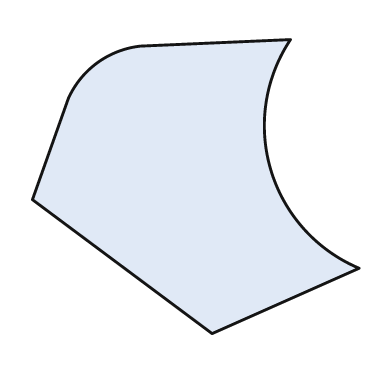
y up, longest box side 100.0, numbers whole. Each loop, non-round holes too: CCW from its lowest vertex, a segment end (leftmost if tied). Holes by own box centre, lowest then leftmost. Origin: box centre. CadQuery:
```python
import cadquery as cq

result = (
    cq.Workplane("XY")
    .moveTo(5.0, -45.0)
    .lineTo(50.0, -25.0)
    .threePointArc((23.0, 5.0), (29.0, 45.0))
    .lineTo(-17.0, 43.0)
    .threePointArc((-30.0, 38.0), (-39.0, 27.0))
    .lineTo(-50.0, -4.0)
    .close()
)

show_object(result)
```